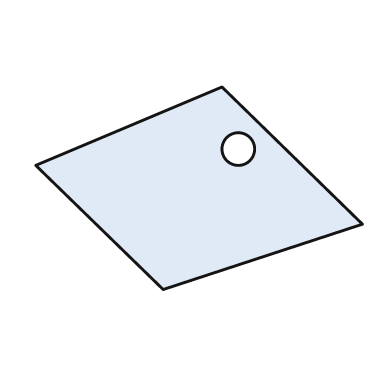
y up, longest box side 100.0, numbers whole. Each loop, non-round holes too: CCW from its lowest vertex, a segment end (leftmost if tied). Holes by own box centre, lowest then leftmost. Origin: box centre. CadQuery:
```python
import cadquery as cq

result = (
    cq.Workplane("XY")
    .moveTo(-11.0, -31.0)
    .lineTo(50.0, -11.0)
    .lineTo(7.0, 31.0)
    .lineTo(-50.0, 7.0)
    .close()
    .moveTo(12.0, 12.0)
    .circle(5.0)
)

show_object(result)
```